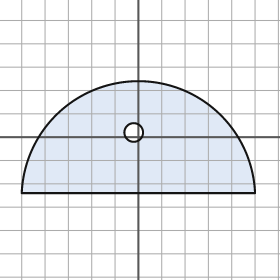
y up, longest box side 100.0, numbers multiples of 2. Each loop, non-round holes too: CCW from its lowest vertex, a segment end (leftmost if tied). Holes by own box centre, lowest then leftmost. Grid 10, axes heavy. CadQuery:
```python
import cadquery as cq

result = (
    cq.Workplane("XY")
    .moveTo(-50.0, -24.0)
    .lineTo(50.0, -24.0)
    .threePointArc((0.0, 24.0), (-50.0, -24.0))
    .close()
    .moveTo(-2.0, 2.0)
    .circle(4.0)
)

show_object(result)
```